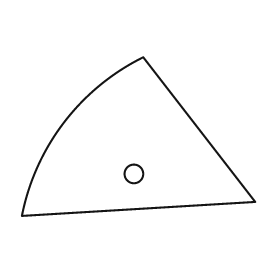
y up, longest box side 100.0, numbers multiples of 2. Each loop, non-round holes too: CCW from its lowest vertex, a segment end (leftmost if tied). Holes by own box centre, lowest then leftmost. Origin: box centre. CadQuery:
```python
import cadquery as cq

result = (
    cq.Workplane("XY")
    .moveTo(-50.0, -34.0)
    .lineTo(50.0, -28.0)
    .lineTo(2.0, 34.0)
    .threePointArc((-32.0, 6.0), (-50.0, -34.0))
    .close()
    .moveTo(-2.0, -16.0)
    .circle(4.0)
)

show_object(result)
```